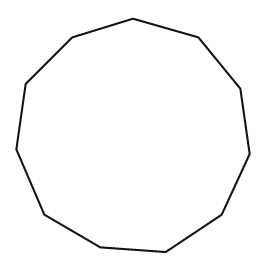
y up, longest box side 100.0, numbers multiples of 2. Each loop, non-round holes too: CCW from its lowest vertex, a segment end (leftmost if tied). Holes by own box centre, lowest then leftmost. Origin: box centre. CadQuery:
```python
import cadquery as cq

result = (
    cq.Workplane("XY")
    .moveTo(14.0, -50.0)
    .lineTo(38.0, -34.0)
    .lineTo(50.0, -8.0)
    .lineTo(46.0, 20.0)
    .lineTo(28.0, 42.0)
    .lineTo(0.0, 50.0)
    .lineTo(-26.0, 42.0)
    .lineTo(-46.0, 22.0)
    .lineTo(-50.0, -6.0)
    .lineTo(-38.0, -34.0)
    .lineTo(-14.0, -48.0)
    .close()
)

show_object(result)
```